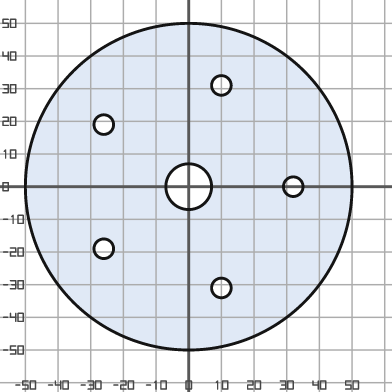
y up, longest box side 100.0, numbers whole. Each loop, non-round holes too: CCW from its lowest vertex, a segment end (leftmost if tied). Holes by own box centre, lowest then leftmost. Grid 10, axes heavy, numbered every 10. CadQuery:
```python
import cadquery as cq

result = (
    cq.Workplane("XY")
    .moveTo(0.0, 0.0)
    .circle(50.0)
    .moveTo(10.0, -31.0)
    .circle(3.0)
    .moveTo(-26.0, -19.0)
    .circle(3.0)
    .moveTo(0.0, 0.0)
    .circle(7.0)
    .moveTo(32.0, 0.0)
    .circle(3.0)
    .moveTo(-26.0, 19.0)
    .circle(3.0)
    .moveTo(10.0, 31.0)
    .circle(3.0)
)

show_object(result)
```